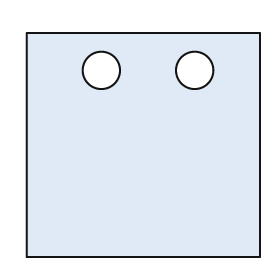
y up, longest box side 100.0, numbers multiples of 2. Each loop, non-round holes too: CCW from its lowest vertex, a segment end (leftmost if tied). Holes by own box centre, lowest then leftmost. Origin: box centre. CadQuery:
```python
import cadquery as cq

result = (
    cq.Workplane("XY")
    .moveTo(-50.0, -48.0)
    .lineTo(50.0, -48.0)
    .lineTo(50.0, 48.0)
    .lineTo(-50.0, 48.0)
    .close()
    .moveTo(-18.0, 32.0)
    .circle(8.0)
    .moveTo(22.0, 32.0)
    .circle(8.0)
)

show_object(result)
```